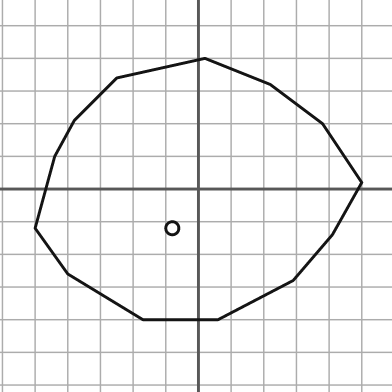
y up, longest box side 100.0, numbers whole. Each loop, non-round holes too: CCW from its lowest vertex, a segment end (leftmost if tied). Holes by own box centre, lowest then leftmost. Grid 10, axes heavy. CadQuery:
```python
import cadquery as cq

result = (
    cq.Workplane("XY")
    .moveTo(-17.0, -40.0)
    .lineTo(6.0, -40.0)
    .lineTo(29.0, -28.0)
    .lineTo(41.0, -14.0)
    .lineTo(50.0, 2.0)
    .lineTo(38.0, 20.0)
    .lineTo(22.0, 32.0)
    .lineTo(2.0, 40.0)
    .lineTo(-25.0, 34.0)
    .lineTo(-38.0, 21.0)
    .lineTo(-44.0, 10.0)
    .lineTo(-50.0, -12.0)
    .lineTo(-40.0, -26.0)
    .close()
    .moveTo(-8.0, -12.0)
    .circle(2.0)
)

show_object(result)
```